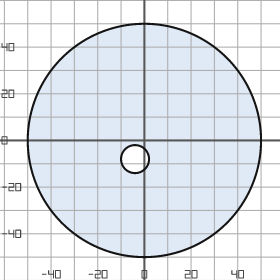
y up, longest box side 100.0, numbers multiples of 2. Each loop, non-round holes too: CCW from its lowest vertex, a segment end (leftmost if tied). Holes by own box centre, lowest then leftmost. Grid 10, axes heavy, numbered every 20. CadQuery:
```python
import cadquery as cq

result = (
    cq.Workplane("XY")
    .moveTo(0.0, 0.0)
    .circle(50.0)
    .moveTo(-4.0, -8.0)
    .circle(6.0)
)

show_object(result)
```